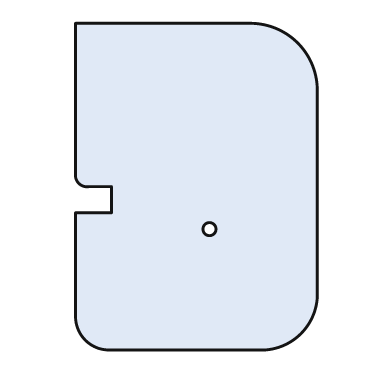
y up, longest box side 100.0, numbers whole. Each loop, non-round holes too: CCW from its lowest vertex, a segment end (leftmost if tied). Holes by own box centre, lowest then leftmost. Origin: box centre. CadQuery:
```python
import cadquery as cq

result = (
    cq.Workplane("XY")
    .moveTo(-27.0, -50.0)
    .lineTo(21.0, -50.0)
    .threePointArc((32.0, -45.0), (37.0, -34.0))
    .lineTo(37.0, 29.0)
    .threePointArc((31.0, 44.0), (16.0, 50.0))
    .lineTo(-37.0, 50.0)
    .lineTo(-37.0, 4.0)
    .threePointArc((-36.0, 1.0), (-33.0, 0.0))
    .lineTo(-26.0, 0.0)
    .lineTo(-26.0, -8.0)
    .lineTo(-37.0, -8.0)
    .lineTo(-37.0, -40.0)
    .threePointArc((-34.0, -47.0), (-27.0, -50.0))
    .close()
    .moveTo(4.0, -13.0)
    .circle(2.0)
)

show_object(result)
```